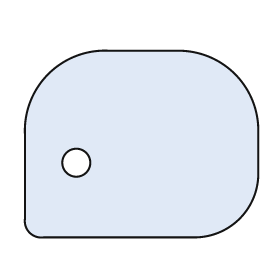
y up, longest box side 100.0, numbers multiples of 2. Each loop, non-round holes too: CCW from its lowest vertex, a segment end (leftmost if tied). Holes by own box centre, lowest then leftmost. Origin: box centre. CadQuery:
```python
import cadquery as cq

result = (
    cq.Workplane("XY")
    .moveTo(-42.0, -40.0)
    .lineTo(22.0, -40.0)
    .threePointArc((42.0, -32.0), (50.0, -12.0))
    .lineTo(50.0, 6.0)
    .threePointArc((40.0, 30.0), (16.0, 40.0))
    .lineTo(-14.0, 40.0)
    .threePointArc((-40.0, 30.0), (-50.0, 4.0))
    .lineTo(-50.0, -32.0)
    .threePointArc((-48.0, -38.0), (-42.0, -40.0))
    .close()
    .moveTo(-28.0, -8.0)
    .circle(6.0)
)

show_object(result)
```